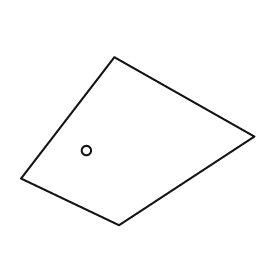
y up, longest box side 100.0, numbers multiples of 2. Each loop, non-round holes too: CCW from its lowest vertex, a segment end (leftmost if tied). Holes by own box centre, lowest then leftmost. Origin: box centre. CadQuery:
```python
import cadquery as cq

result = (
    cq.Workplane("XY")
    .moveTo(-8.0, -36.0)
    .lineTo(50.0, 2.0)
    .lineTo(-10.0, 36.0)
    .lineTo(-50.0, -16.0)
    .close()
    .moveTo(-22.0, -4.0)
    .circle(2.0)
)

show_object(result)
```